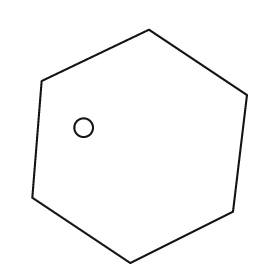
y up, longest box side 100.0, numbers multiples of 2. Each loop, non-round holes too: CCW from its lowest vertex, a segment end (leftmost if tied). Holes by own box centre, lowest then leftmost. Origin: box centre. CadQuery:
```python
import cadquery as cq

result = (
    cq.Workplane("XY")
    .moveTo(-4.0, -50.0)
    .lineTo(40.0, -28.0)
    .lineTo(46.0, 22.0)
    .lineTo(4.0, 50.0)
    .lineTo(-42.0, 28.0)
    .lineTo(-46.0, -22.0)
    .close()
    .moveTo(-24.0, 8.0)
    .circle(4.0)
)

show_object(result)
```